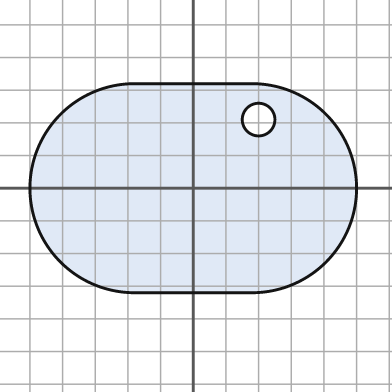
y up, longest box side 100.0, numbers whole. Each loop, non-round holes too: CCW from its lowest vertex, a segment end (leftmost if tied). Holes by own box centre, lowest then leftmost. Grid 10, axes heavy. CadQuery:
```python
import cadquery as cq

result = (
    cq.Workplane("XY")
    .moveTo(-18.0, -32.0)
    .lineTo(18.0, -32.0)
    .threePointArc((50.0, 0.0), (18.0, 32.0))
    .lineTo(-18.0, 32.0)
    .threePointArc((-50.0, 0.0), (-18.0, -32.0))
    .close()
    .moveTo(20.0, 21.0)
    .circle(5.0)
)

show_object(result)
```